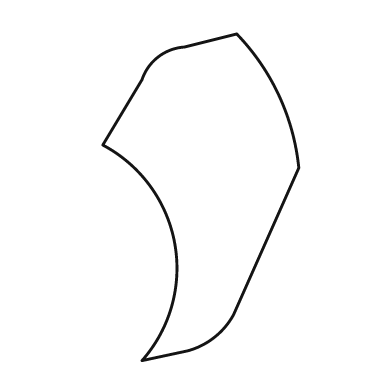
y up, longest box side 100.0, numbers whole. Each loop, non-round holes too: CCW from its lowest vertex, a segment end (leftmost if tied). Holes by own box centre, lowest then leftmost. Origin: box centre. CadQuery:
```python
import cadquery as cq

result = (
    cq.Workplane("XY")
    .moveTo(-18.0, -50.0)
    .lineTo(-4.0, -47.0)
    .threePointArc((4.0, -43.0), (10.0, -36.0))
    .lineTo(30.0, 9.0)
    .threePointArc((24.0, 31.0), (11.0, 50.0))
    .lineTo(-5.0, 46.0)
    .threePointArc((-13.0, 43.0), (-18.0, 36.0))
    .lineTo(-30.0, 16.0)
    .threePointArc((-8.0, -14.0), (-18.0, -50.0))
    .close()
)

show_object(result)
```